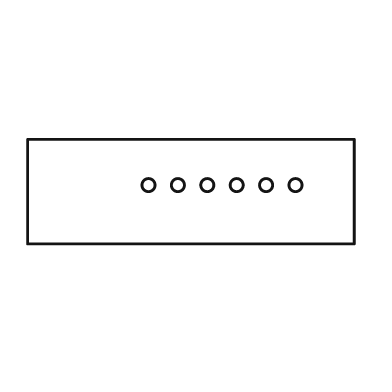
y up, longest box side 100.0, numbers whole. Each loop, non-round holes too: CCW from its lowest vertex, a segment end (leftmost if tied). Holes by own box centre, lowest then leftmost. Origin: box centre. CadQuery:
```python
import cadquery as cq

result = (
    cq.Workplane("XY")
    .moveTo(-50.0, -16.0)
    .lineTo(50.0, -16.0)
    .lineTo(50.0, 16.0)
    .lineTo(-50.0, 16.0)
    .close()
    .moveTo(-13.0, 2.0)
    .circle(2.0)
    .moveTo(-4.0, 2.0)
    .circle(2.0)
    .moveTo(5.0, 2.0)
    .circle(2.0)
    .moveTo(14.0, 2.0)
    .circle(2.0)
    .moveTo(23.0, 2.0)
    .circle(2.0)
    .moveTo(32.0, 2.0)
    .circle(2.0)
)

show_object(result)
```